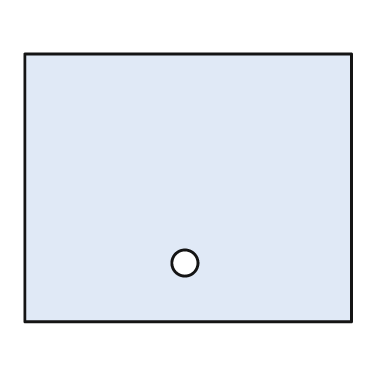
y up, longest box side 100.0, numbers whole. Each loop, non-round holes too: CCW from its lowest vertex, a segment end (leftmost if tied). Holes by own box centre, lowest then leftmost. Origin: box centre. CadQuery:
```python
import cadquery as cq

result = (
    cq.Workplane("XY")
    .moveTo(-50.0, -41.0)
    .lineTo(50.0, -41.0)
    .lineTo(50.0, 41.0)
    .lineTo(-50.0, 41.0)
    .close()
    .moveTo(-1.0, -23.0)
    .circle(4.0)
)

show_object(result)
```